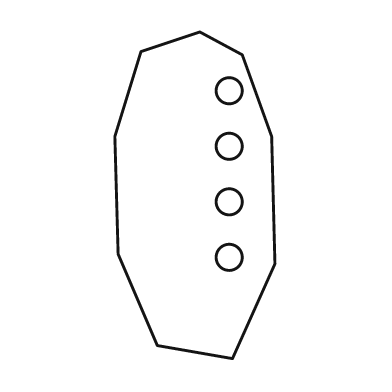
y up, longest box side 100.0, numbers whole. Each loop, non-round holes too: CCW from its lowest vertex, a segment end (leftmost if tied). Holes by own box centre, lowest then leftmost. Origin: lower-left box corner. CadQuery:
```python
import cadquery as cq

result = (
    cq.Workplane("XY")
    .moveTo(36.0, 0.0)
    .lineTo(49.0, 29.0)
    .lineTo(48.0, 68.0)
    .lineTo(39.0, 93.0)
    .lineTo(26.0, 100.0)
    .lineTo(8.0, 94.0)
    .lineTo(0.0, 68.0)
    .lineTo(1.0, 32.0)
    .lineTo(13.0, 4.0)
    .close()
    .moveTo(35.0, 31.0)
    .circle(4.0)
    .moveTo(35.0, 48.0)
    .circle(4.0)
    .moveTo(35.0, 65.0)
    .circle(4.0)
    .moveTo(35.0, 82.0)
    .circle(4.0)
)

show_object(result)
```